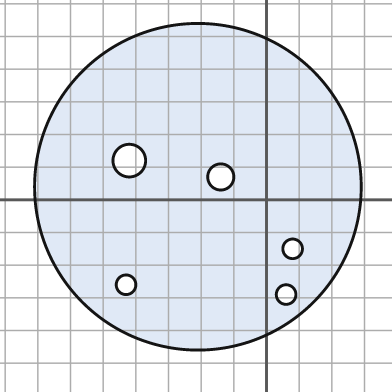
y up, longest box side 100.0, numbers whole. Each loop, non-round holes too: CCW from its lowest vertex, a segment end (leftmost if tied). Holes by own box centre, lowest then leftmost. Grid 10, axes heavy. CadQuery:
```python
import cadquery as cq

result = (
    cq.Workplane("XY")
    .moveTo(-21.0, 4.0)
    .circle(50.0)
    .moveTo(6.0, -29.0)
    .circle(3.0)
    .moveTo(-43.0, -26.0)
    .circle(3.0)
    .moveTo(8.0, -15.0)
    .circle(3.0)
    .moveTo(-14.0, 7.0)
    .circle(4.0)
    .moveTo(-42.0, 12.0)
    .circle(5.0)
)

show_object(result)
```